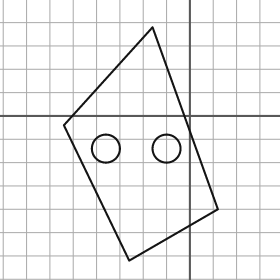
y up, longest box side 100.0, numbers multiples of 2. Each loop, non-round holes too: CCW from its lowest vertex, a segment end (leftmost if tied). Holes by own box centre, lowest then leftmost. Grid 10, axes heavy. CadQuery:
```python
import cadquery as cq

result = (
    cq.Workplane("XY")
    .moveTo(-26.0, -62.0)
    .lineTo(12.0, -40.0)
    .lineTo(-16.0, 38.0)
    .lineTo(-54.0, -4.0)
    .close()
    .moveTo(-36.0, -14.0)
    .circle(6.0)
    .moveTo(-10.0, -14.0)
    .circle(6.0)
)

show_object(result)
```